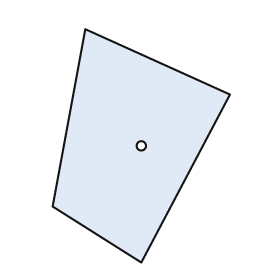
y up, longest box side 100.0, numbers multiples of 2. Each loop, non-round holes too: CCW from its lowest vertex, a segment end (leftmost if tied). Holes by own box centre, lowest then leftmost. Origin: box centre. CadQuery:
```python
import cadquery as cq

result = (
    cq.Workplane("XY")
    .moveTo(0.0, -50.0)
    .lineTo(38.0, 22.0)
    .lineTo(-24.0, 50.0)
    .lineTo(-38.0, -26.0)
    .close()
    .moveTo(0.0, 0.0)
    .circle(2.0)
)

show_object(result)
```